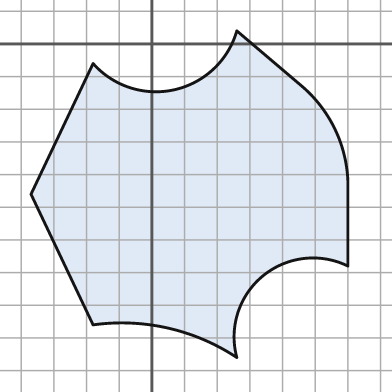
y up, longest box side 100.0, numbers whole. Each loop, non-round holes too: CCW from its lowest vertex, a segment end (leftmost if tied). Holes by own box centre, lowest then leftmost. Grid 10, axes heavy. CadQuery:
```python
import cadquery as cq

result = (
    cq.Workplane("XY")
    .moveTo(26.0, -96.0)
    .threePointArc((34.0, -71.0), (60.0, -68.0))
    .lineTo(60.0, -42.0)
    .threePointArc((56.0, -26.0), (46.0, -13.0))
    .lineTo(26.0, 4.0)
    .threePointArc((7.0, -14.0), (-18.0, -6.0))
    .lineTo(-37.0, -46.0)
    .lineTo(-18.0, -86.0)
    .threePointArc((5.0, -87.0), (26.0, -96.0))
    .close()
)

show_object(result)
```